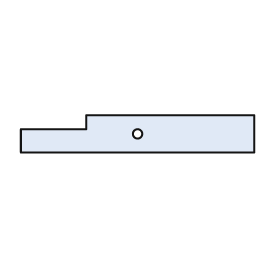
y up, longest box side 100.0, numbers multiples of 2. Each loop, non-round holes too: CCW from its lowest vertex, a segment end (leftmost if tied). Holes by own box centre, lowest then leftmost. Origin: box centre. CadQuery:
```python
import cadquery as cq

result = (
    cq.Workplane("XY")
    .moveTo(-50.0, -8.0)
    .lineTo(50.0, -8.0)
    .lineTo(50.0, 8.0)
    .lineTo(-22.0, 8.0)
    .lineTo(-22.0, 2.0)
    .lineTo(-50.0, 2.0)
    .close()
    .moveTo(0.0, 0.0)
    .circle(2.0)
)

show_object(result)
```